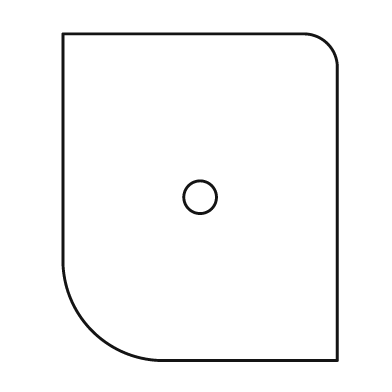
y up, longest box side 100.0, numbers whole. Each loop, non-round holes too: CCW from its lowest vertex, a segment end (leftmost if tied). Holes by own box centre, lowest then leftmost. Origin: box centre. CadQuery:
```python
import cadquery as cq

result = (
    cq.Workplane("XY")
    .moveTo(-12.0, -50.0)
    .lineTo(42.0, -50.0)
    .lineTo(42.0, 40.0)
    .threePointArc((39.0, 47.0), (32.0, 50.0))
    .lineTo(-42.0, 50.0)
    .lineTo(-42.0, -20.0)
    .threePointArc((-33.0, -41.0), (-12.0, -50.0))
    .close()
    .moveTo(0.0, 0.0)
    .circle(5.0)
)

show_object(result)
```